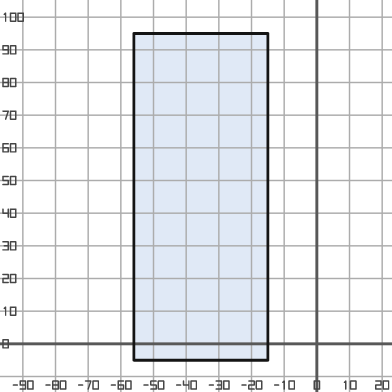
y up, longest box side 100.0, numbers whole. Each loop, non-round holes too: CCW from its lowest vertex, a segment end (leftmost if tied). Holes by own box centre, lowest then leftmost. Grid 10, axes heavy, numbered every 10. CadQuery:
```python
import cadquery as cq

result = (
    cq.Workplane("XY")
    .moveTo(-56.0, -5.0)
    .lineTo(-15.0, -5.0)
    .lineTo(-15.0, 95.0)
    .lineTo(-56.0, 95.0)
    .close()
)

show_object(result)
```